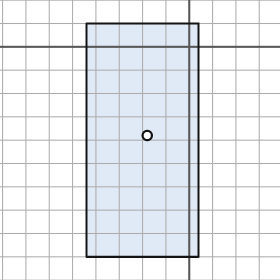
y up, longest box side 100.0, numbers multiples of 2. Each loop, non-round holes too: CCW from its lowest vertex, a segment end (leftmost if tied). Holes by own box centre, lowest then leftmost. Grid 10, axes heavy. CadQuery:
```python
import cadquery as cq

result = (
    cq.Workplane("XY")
    .moveTo(-44.0, -90.0)
    .lineTo(4.0, -90.0)
    .lineTo(4.0, 10.0)
    .lineTo(-44.0, 10.0)
    .close()
    .moveTo(-18.0, -38.0)
    .circle(2.0)
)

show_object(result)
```